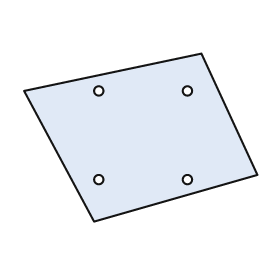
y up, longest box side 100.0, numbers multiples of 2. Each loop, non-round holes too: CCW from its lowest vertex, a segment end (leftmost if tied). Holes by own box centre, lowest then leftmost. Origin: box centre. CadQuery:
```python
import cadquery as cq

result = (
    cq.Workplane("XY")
    .moveTo(-20.0, -36.0)
    .lineTo(50.0, -16.0)
    .lineTo(26.0, 36.0)
    .lineTo(-50.0, 20.0)
    .close()
    .moveTo(-18.0, -18.0)
    .circle(2.0)
    .moveTo(20.0, -18.0)
    .circle(2.0)
    .moveTo(-18.0, 20.0)
    .circle(2.0)
    .moveTo(20.0, 20.0)
    .circle(2.0)
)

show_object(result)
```